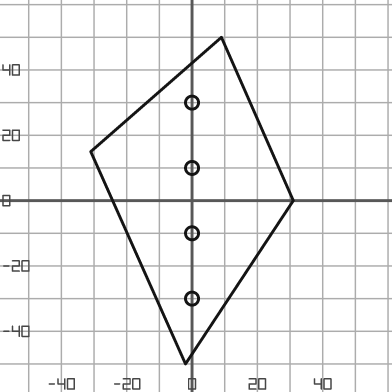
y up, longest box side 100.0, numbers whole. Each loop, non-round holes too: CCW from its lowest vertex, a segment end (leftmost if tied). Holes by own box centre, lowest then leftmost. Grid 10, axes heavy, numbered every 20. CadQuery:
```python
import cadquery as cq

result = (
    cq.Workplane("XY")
    .moveTo(-2.0, -50.0)
    .lineTo(31.0, 0.0)
    .lineTo(9.0, 50.0)
    .lineTo(-31.0, 15.0)
    .close()
    .moveTo(0.0, -30.0)
    .circle(2.0)
    .moveTo(0.0, -10.0)
    .circle(2.0)
    .moveTo(0.0, 10.0)
    .circle(2.0)
    .moveTo(0.0, 30.0)
    .circle(2.0)
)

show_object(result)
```